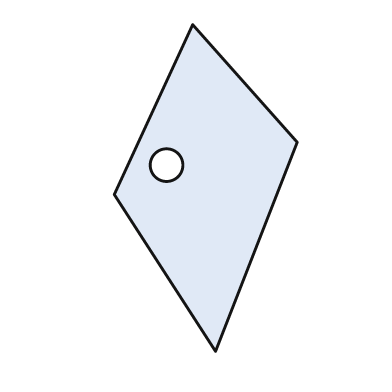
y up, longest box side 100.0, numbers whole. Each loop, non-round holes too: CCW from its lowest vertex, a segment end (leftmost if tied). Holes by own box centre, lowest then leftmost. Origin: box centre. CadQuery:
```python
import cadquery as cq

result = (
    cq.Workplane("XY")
    .moveTo(3.0, -50.0)
    .lineTo(28.0, 14.0)
    .lineTo(-4.0, 50.0)
    .lineTo(-28.0, -2.0)
    .close()
    .moveTo(-12.0, 7.0)
    .circle(5.0)
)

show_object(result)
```